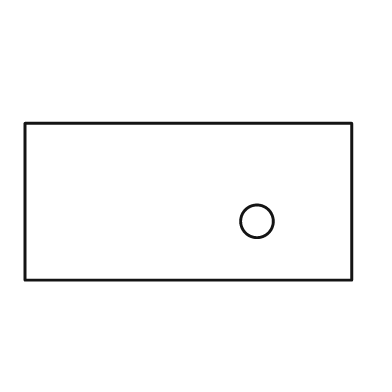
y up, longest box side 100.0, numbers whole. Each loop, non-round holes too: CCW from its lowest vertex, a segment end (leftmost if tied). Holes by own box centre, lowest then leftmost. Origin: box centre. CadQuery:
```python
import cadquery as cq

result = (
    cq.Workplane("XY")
    .moveTo(-50.0, -24.0)
    .lineTo(50.0, -24.0)
    .lineTo(50.0, 24.0)
    .lineTo(-50.0, 24.0)
    .close()
    .moveTo(21.0, -6.0)
    .circle(5.0)
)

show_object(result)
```